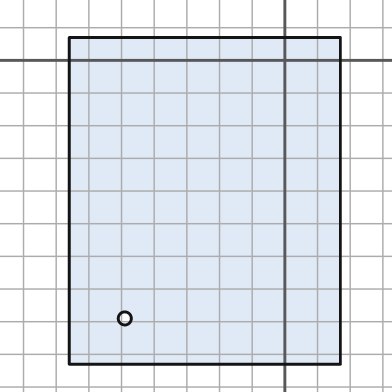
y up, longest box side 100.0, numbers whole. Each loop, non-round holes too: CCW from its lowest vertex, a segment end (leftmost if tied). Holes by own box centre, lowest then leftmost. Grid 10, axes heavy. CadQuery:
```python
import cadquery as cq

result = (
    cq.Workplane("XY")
    .moveTo(-66.0, -93.0)
    .lineTo(17.0, -93.0)
    .lineTo(17.0, 7.0)
    .lineTo(-66.0, 7.0)
    .close()
    .moveTo(-49.0, -79.0)
    .circle(2.0)
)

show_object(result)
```